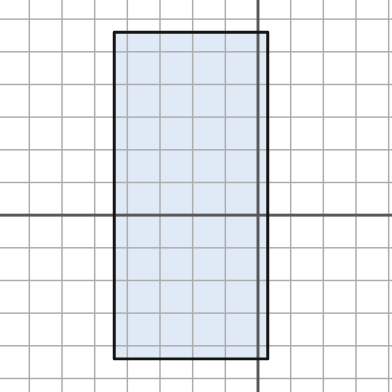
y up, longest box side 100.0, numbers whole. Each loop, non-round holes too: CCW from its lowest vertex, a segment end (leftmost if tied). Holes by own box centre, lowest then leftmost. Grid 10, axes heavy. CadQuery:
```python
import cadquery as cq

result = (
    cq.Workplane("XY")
    .moveTo(-44.0, -44.0)
    .lineTo(3.0, -44.0)
    .lineTo(3.0, 56.0)
    .lineTo(-44.0, 56.0)
    .close()
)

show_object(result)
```